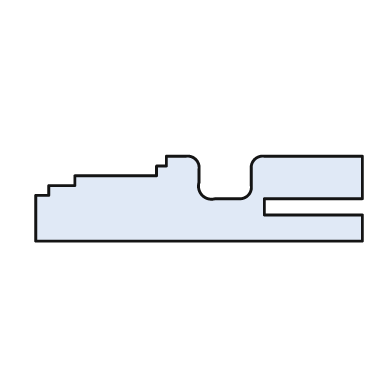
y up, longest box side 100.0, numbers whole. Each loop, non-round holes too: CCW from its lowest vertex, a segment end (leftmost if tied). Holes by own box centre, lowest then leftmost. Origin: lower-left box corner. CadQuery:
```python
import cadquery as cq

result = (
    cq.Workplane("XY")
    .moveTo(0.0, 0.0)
    .lineTo(100.0, 0.0)
    .lineTo(100.0, 8.0)
    .lineTo(70.0, 8.0)
    .lineTo(70.0, 13.0)
    .lineTo(100.0, 13.0)
    .lineTo(100.0, 26.0)
    .lineTo(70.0, 26.0)
    .threePointArc((67.0, 25.0), (66.0, 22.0))
    .lineTo(66.0, 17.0)
    .threePointArc((65.0, 14.0), (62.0, 13.0))
    .lineTo(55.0, 13.0)
    .threePointArc((51.0, 14.0), (50.0, 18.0))
    .lineTo(50.0, 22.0)
    .threePointArc((49.0, 25.0), (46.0, 26.0))
    .lineTo(40.0, 26.0)
    .lineTo(40.0, 23.0)
    .lineTo(37.0, 23.0)
    .lineTo(37.0, 20.0)
    .lineTo(12.0, 20.0)
    .lineTo(12.0, 17.0)
    .lineTo(4.0, 17.0)
    .lineTo(4.0, 14.0)
    .lineTo(0.0, 14.0)
    .close()
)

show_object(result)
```